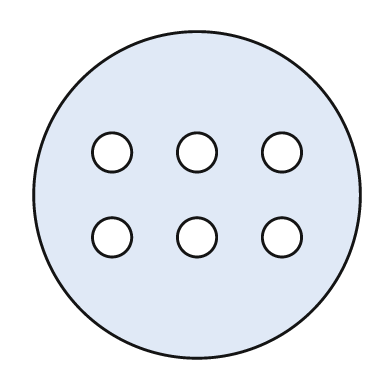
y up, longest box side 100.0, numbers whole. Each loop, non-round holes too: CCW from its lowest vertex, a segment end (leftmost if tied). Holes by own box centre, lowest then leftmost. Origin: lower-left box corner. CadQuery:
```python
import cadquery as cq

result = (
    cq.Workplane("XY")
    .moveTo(50.0, 50.0)
    .circle(50.0)
    .moveTo(24.0, 37.0)
    .circle(6.0)
    .moveTo(50.0, 37.0)
    .circle(6.0)
    .moveTo(76.0, 37.0)
    .circle(6.0)
    .moveTo(24.0, 63.0)
    .circle(6.0)
    .moveTo(50.0, 63.0)
    .circle(6.0)
    .moveTo(76.0, 63.0)
    .circle(6.0)
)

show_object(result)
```